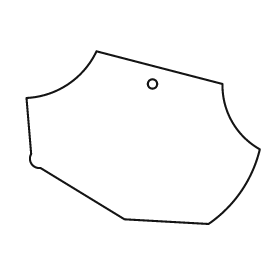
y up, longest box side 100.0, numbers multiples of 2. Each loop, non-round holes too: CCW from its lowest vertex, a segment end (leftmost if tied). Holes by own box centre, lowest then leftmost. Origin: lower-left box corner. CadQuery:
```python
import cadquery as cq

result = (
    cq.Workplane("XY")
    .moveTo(78.0, 0.0)
    .threePointArc((92.0, 14.0), (100.0, 32.0))
    .threePointArc((88.0, 44.0), (84.0, 60.0))
    .lineTo(30.0, 74.0)
    .threePointArc((18.0, 60.0), (0.0, 54.0))
    .lineTo(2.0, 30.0)
    .threePointArc((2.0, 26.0), (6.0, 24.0))
    .lineTo(42.0, 2.0)
    .close()
    .moveTo(54.0, 60.0)
    .circle(2.0)
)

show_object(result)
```